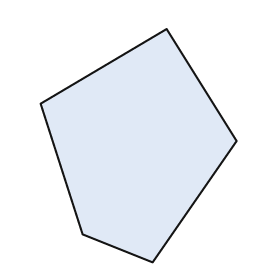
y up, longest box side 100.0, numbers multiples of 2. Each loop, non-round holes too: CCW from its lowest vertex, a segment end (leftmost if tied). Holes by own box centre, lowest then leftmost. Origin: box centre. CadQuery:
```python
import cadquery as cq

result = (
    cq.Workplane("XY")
    .moveTo(6.0, -50.0)
    .lineTo(42.0, 2.0)
    .lineTo(12.0, 50.0)
    .lineTo(-42.0, 18.0)
    .lineTo(-24.0, -38.0)
    .close()
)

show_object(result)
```